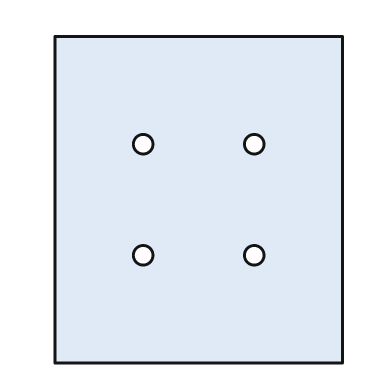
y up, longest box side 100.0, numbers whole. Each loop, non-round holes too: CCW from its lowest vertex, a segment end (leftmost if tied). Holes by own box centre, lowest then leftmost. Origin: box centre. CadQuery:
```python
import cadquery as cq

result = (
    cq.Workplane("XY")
    .moveTo(-44.0, -50.0)
    .lineTo(44.0, -50.0)
    .lineTo(44.0, 50.0)
    .lineTo(-44.0, 50.0)
    .close()
    .moveTo(-17.0, -17.0)
    .circle(3.0)
    .moveTo(17.0, -17.0)
    .circle(3.0)
    .moveTo(-17.0, 17.0)
    .circle(3.0)
    .moveTo(17.0, 17.0)
    .circle(3.0)
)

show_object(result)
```